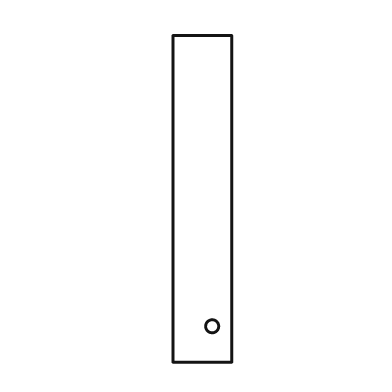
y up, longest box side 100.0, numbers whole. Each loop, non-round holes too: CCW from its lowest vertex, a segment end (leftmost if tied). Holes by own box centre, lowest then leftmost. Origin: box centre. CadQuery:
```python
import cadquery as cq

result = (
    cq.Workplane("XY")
    .moveTo(-9.0, -50.0)
    .lineTo(9.0, -50.0)
    .lineTo(9.0, 50.0)
    .lineTo(-9.0, 50.0)
    .close()
    .moveTo(3.0, -39.0)
    .circle(2.0)
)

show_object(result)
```